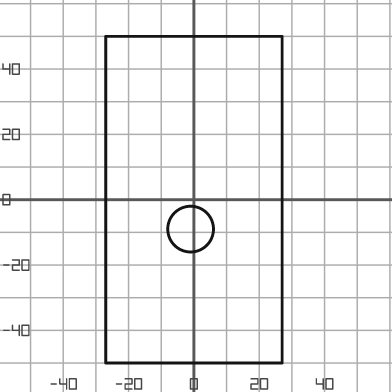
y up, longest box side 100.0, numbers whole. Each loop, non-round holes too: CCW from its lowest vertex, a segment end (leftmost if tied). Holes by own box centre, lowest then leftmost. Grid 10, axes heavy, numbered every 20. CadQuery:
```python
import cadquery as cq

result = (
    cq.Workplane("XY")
    .moveTo(-27.0, -50.0)
    .lineTo(27.0, -50.0)
    .lineTo(27.0, 50.0)
    .lineTo(-27.0, 50.0)
    .close()
    .moveTo(-1.0, -9.0)
    .circle(7.0)
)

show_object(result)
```